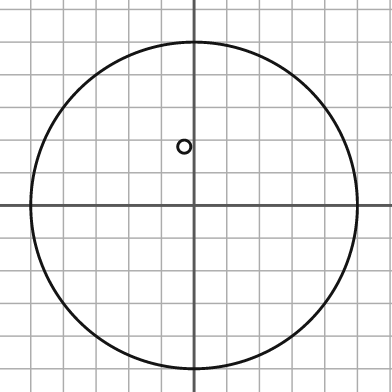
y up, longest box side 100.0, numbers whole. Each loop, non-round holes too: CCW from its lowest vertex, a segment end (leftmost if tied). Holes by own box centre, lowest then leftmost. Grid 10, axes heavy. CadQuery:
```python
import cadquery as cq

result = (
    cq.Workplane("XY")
    .moveTo(0.0, 0.0)
    .circle(50.0)
    .moveTo(-3.0, 18.0)
    .circle(2.0)
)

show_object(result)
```